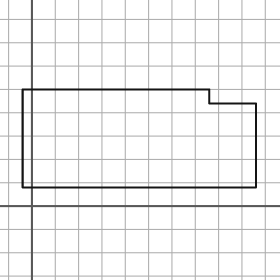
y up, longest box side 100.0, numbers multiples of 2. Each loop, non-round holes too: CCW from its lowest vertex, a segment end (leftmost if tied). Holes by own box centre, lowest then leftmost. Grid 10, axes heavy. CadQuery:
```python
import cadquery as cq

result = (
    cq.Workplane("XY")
    .moveTo(-4.0, 8.0)
    .lineTo(96.0, 8.0)
    .lineTo(96.0, 44.0)
    .lineTo(76.0, 44.0)
    .lineTo(76.0, 50.0)
    .lineTo(-4.0, 50.0)
    .close()
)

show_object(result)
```